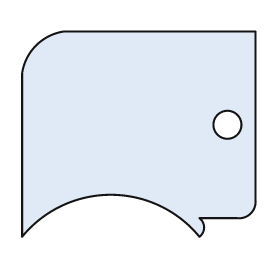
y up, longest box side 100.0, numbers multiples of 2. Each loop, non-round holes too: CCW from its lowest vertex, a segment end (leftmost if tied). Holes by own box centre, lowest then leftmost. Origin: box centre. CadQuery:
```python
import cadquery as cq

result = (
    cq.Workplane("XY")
    .moveTo(-50.0, -44.0)
    .threePointArc((-12.0, -26.0), (26.0, -44.0))
    .threePointArc((28.0, -40.0), (26.0, -36.0))
    .lineTo(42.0, -36.0)
    .threePointArc((48.0, -34.0), (50.0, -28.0))
    .lineTo(50.0, 44.0)
    .lineTo(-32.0, 44.0)
    .threePointArc((-44.0, 38.0), (-50.0, 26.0))
    .close()
    .moveTo(38.0, 4.0)
    .circle(6.0)
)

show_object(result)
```